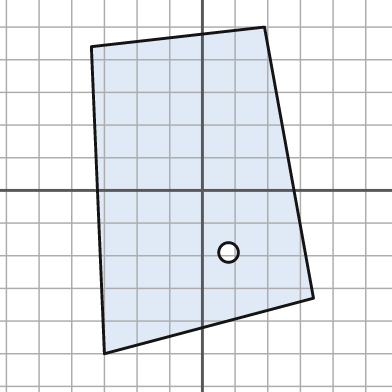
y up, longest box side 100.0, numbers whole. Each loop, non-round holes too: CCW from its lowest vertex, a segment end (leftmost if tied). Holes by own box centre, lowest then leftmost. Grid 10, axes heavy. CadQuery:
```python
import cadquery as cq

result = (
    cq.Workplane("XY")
    .moveTo(-30.0, -50.0)
    .lineTo(34.0, -33.0)
    .lineTo(19.0, 50.0)
    .lineTo(-34.0, 44.0)
    .close()
    .moveTo(8.0, -19.0)
    .circle(3.0)
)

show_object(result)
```